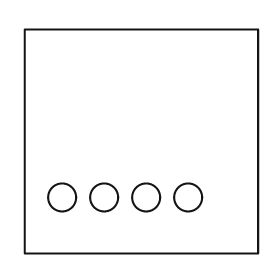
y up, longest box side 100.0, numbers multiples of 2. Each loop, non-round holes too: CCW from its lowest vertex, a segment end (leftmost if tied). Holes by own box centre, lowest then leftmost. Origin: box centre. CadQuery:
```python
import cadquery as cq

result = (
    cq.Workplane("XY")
    .moveTo(-50.0, -48.0)
    .lineTo(50.0, -48.0)
    .lineTo(50.0, 48.0)
    .lineTo(-50.0, 48.0)
    .close()
    .moveTo(-34.0, -24.0)
    .circle(6.0)
    .moveTo(-16.0, -24.0)
    .circle(6.0)
    .moveTo(2.0, -24.0)
    .circle(6.0)
    .moveTo(20.0, -24.0)
    .circle(6.0)
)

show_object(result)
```